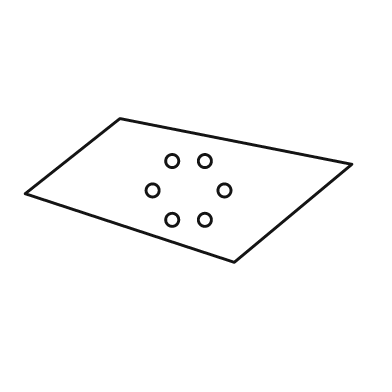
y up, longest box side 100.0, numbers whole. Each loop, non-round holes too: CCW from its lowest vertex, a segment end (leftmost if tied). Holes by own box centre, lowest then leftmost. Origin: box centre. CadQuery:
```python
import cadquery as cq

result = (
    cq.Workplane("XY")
    .moveTo(14.0, -22.0)
    .lineTo(50.0, 8.0)
    .lineTo(-21.0, 22.0)
    .lineTo(-50.0, -1.0)
    .close()
    .moveTo(-5.0, -9.0)
    .circle(2.0)
    .moveTo(5.0, -9.0)
    .circle(2.0)
    .moveTo(-11.0, 0.0)
    .circle(2.0)
    .moveTo(11.0, 0.0)
    .circle(2.0)
    .moveTo(-5.0, 9.0)
    .circle(2.0)
    .moveTo(5.0, 9.0)
    .circle(2.0)
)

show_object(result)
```